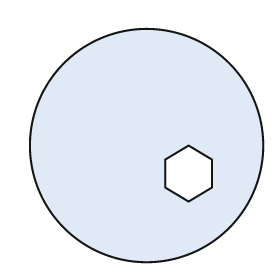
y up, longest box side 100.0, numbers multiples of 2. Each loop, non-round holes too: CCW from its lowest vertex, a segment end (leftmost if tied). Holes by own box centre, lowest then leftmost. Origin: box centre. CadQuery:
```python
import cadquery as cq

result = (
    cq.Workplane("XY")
    .moveTo(0.0, 0.0)
    .circle(50.0)
    .moveTo(18.0, -24.0)
    .lineTo(28.0, -18.0)
    .lineTo(28.0, -6.0)
    .lineTo(18.0, 0.0)
    .lineTo(8.0, -6.0)
    .lineTo(8.0, -18.0)
    .close()
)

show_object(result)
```